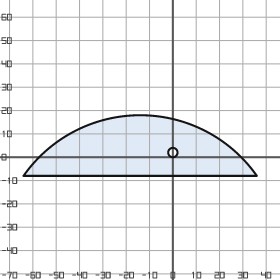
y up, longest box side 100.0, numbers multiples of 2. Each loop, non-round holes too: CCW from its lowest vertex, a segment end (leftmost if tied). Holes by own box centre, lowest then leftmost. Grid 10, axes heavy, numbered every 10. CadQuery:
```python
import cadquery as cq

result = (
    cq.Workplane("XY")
    .moveTo(-64.0, -8.0)
    .lineTo(36.0, -8.0)
    .threePointArc((-14.0, 18.0), (-64.0, -8.0))
    .close()
    .moveTo(0.0, 2.0)
    .circle(2.0)
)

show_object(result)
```